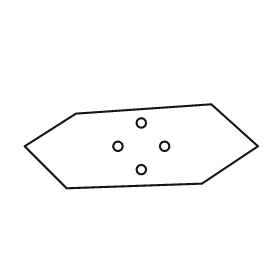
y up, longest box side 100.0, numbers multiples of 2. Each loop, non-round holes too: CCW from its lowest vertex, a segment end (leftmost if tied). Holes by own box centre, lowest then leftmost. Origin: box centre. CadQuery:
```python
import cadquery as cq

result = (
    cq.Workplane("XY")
    .moveTo(-32.0, -18.0)
    .lineTo(26.0, -16.0)
    .lineTo(50.0, 0.0)
    .lineTo(30.0, 18.0)
    .lineTo(-28.0, 14.0)
    .lineTo(-50.0, 0.0)
    .close()
    .moveTo(0.0, -10.0)
    .circle(2.0)
    .moveTo(-10.0, 0.0)
    .circle(2.0)
    .moveTo(10.0, 0.0)
    .circle(2.0)
    .moveTo(0.0, 10.0)
    .circle(2.0)
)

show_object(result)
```